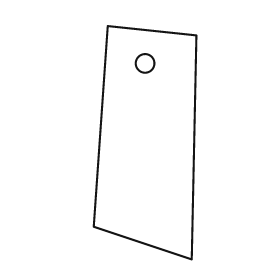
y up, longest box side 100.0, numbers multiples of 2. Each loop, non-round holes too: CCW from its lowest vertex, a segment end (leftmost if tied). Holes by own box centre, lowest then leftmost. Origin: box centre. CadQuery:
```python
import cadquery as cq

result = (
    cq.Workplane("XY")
    .moveTo(20.0, -50.0)
    .lineTo(22.0, 46.0)
    .lineTo(-16.0, 50.0)
    .lineTo(-22.0, -36.0)
    .close()
    .moveTo(0.0, 34.0)
    .circle(4.0)
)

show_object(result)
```